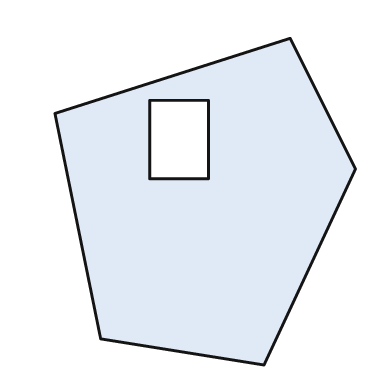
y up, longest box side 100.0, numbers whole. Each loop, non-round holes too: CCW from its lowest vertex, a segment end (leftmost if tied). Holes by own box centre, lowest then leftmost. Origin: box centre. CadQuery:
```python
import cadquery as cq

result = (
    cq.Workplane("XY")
    .moveTo(18.0, -50.0)
    .lineTo(46.0, 10.0)
    .lineTo(26.0, 50.0)
    .lineTo(-46.0, 27.0)
    .lineTo(-32.0, -42.0)
    .close()
    .moveTo(-17.0, 7.0)
    .lineTo(1.0, 7.0)
    .lineTo(1.0, 31.0)
    .lineTo(-17.0, 31.0)
    .close()
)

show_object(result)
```